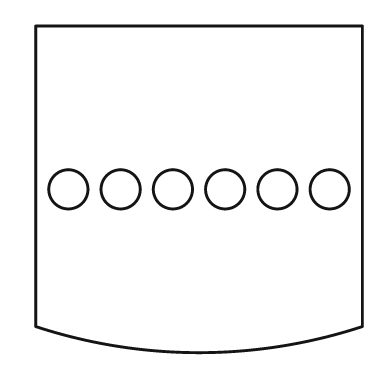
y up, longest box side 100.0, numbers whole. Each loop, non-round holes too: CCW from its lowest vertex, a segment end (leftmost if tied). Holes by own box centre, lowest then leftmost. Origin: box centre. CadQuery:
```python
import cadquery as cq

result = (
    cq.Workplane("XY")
    .moveTo(-50.0, -42.0)
    .threePointArc((0.0, -50.0), (50.0, -42.0))
    .lineTo(50.0, 50.0)
    .lineTo(-50.0, 50.0)
    .close()
    .moveTo(-40.0, 0.0)
    .circle(6.0)
    .moveTo(-24.0, 0.0)
    .circle(6.0)
    .moveTo(-8.0, 0.0)
    .circle(6.0)
    .moveTo(8.0, 0.0)
    .circle(6.0)
    .moveTo(24.0, 0.0)
    .circle(6.0)
    .moveTo(40.0, 0.0)
    .circle(6.0)
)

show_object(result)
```